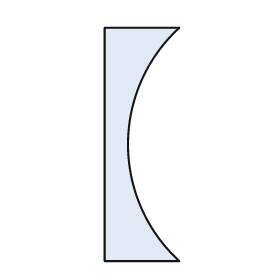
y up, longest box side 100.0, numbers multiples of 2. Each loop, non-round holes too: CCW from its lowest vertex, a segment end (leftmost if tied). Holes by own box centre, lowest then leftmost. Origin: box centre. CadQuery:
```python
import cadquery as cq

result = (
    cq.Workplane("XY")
    .moveTo(-16.0, -50.0)
    .lineTo(16.0, -50.0)
    .threePointArc((-6.0, 0.0), (16.0, 50.0))
    .lineTo(-16.0, 50.0)
    .close()
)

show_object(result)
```